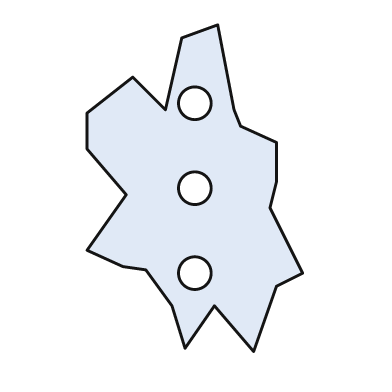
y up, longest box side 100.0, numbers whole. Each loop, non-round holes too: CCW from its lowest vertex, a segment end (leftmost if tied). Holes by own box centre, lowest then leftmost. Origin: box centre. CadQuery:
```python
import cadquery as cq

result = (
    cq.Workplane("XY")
    .moveTo(18.0, -50.0)
    .lineTo(25.0, -30.0)
    .lineTo(33.0, -26.0)
    .lineTo(23.0, -6.0)
    .lineTo(25.0, 2.0)
    .lineTo(25.0, 14.0)
    .lineTo(14.0, 19.0)
    .lineTo(12.0, 24.0)
    .lineTo(7.0, 50.0)
    .lineTo(-4.0, 46.0)
    .lineTo(-9.0, 24.0)
    .lineTo(-19.0, 34.0)
    .lineTo(-33.0, 23.0)
    .lineTo(-33.0, 12.0)
    .lineTo(-21.0, -2.0)
    .lineTo(-33.0, -19.0)
    .lineTo(-22.0, -24.0)
    .lineTo(-15.0, -25.0)
    .lineTo(-7.0, -36.0)
    .lineTo(-3.0, -49.0)
    .lineTo(6.0, -36.0)
    .close()
    .moveTo(0.0, -26.0)
    .circle(5.0)
    .moveTo(0.0, 0.0)
    .circle(5.0)
    .moveTo(0.0, 26.0)
    .circle(5.0)
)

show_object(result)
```